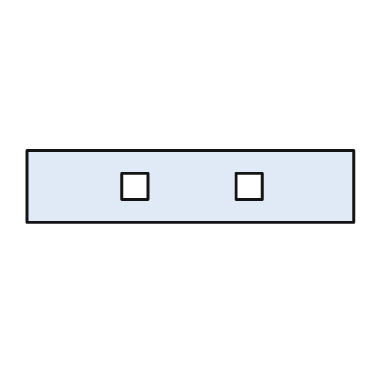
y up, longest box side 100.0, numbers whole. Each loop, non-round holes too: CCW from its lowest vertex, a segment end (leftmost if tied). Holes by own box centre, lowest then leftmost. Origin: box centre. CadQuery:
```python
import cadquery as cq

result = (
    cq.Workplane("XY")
    .moveTo(-50.0, -11.0)
    .lineTo(50.0, -11.0)
    .lineTo(50.0, 11.0)
    .lineTo(-50.0, 11.0)
    .close()
    .moveTo(-21.0, -4.0)
    .lineTo(-13.0, -4.0)
    .lineTo(-13.0, 4.0)
    .lineTo(-21.0, 4.0)
    .close()
    .moveTo(14.0, -4.0)
    .lineTo(22.0, -4.0)
    .lineTo(22.0, 4.0)
    .lineTo(14.0, 4.0)
    .close()
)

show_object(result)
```